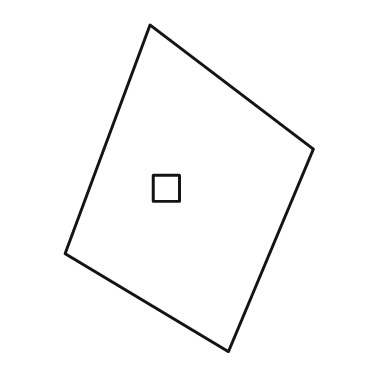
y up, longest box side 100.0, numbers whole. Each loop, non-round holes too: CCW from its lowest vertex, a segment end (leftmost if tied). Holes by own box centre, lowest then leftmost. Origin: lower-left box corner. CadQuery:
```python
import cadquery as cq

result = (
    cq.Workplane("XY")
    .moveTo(50.0, 0.0)
    .lineTo(76.0, 62.0)
    .lineTo(26.0, 100.0)
    .lineTo(0.0, 30.0)
    .close()
    .moveTo(27.0, 46.0)
    .lineTo(35.0, 46.0)
    .lineTo(35.0, 54.0)
    .lineTo(27.0, 54.0)
    .close()
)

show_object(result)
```